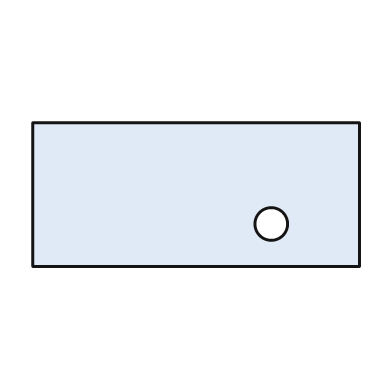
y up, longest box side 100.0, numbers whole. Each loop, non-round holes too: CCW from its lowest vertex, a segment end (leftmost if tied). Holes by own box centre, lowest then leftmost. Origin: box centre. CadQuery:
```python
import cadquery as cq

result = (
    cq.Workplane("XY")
    .moveTo(-50.0, -22.0)
    .lineTo(50.0, -22.0)
    .lineTo(50.0, 22.0)
    .lineTo(-50.0, 22.0)
    .close()
    .moveTo(23.0, -9.0)
    .circle(5.0)
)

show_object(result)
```